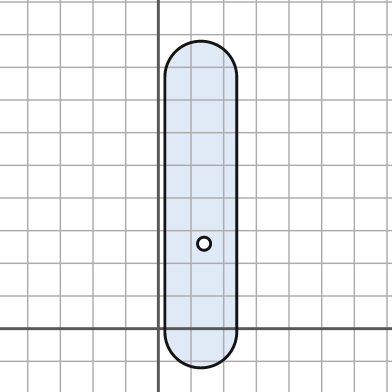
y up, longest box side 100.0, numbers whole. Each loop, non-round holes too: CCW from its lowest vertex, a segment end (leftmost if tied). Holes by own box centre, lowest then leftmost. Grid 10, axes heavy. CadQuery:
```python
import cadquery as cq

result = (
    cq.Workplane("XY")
    .moveTo(2.0, -1.0)
    .threePointArc((13.0, -12.0), (24.0, -1.0))
    .lineTo(24.0, 77.0)
    .threePointArc((13.0, 88.0), (2.0, 77.0))
    .close()
    .moveTo(14.0, 26.0)
    .circle(2.0)
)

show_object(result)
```